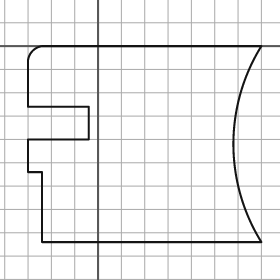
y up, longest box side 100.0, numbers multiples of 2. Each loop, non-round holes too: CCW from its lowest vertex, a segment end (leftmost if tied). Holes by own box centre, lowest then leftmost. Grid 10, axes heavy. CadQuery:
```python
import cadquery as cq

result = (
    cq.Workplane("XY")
    .moveTo(-24.0, -84.0)
    .lineTo(70.0, -84.0)
    .threePointArc((58.0, -42.0), (70.0, 0.0))
    .lineTo(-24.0, 0.0)
    .threePointArc((-28.0, -2.0), (-30.0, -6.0))
    .lineTo(-30.0, -26.0)
    .lineTo(-4.0, -26.0)
    .lineTo(-4.0, -40.0)
    .lineTo(-30.0, -40.0)
    .lineTo(-30.0, -54.0)
    .lineTo(-24.0, -54.0)
    .close()
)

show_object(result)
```